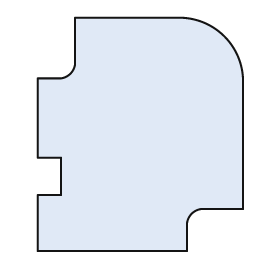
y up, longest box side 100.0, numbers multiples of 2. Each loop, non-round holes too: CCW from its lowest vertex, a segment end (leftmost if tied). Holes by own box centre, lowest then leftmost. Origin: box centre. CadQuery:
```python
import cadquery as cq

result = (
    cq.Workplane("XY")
    .moveTo(-44.0, -50.0)
    .lineTo(20.0, -50.0)
    .lineTo(20.0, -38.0)
    .threePointArc((22.0, -34.0), (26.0, -32.0))
    .lineTo(44.0, -32.0)
    .lineTo(44.0, 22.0)
    .threePointArc((36.0, 42.0), (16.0, 50.0))
    .lineTo(-28.0, 50.0)
    .lineTo(-28.0, 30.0)
    .threePointArc((-30.0, 26.0), (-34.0, 24.0))
    .lineTo(-44.0, 24.0)
    .lineTo(-44.0, -10.0)
    .lineTo(-34.0, -10.0)
    .lineTo(-34.0, -26.0)
    .lineTo(-44.0, -26.0)
    .close()
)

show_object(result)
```